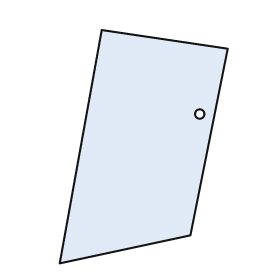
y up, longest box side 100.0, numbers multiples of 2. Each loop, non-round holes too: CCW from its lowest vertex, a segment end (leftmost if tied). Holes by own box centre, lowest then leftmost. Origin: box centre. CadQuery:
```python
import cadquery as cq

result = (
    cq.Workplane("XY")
    .moveTo(-36.0, -50.0)
    .lineTo(20.0, -38.0)
    .lineTo(36.0, 42.0)
    .lineTo(-18.0, 50.0)
    .close()
    .moveTo(24.0, 14.0)
    .circle(2.0)
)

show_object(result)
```